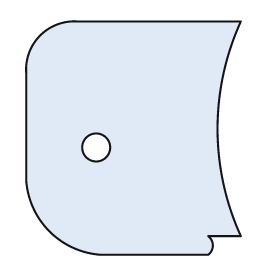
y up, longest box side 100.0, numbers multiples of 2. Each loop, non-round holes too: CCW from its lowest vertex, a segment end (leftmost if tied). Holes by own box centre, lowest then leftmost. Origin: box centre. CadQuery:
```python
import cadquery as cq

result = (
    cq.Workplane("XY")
    .moveTo(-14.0, -50.0)
    .lineTo(32.0, -50.0)
    .threePointArc((34.0, -46.0), (32.0, -42.0))
    .lineTo(46.0, -42.0)
    .threePointArc((36.0, 4.0), (46.0, 50.0))
    .lineTo(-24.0, 50.0)
    .threePointArc((-40.0, 44.0), (-46.0, 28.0))
    .lineTo(-46.0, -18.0)
    .threePointArc((-36.0, -40.0), (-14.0, -50.0))
    .close()
    .moveTo(-16.0, -4.0)
    .circle(6.0)
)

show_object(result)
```